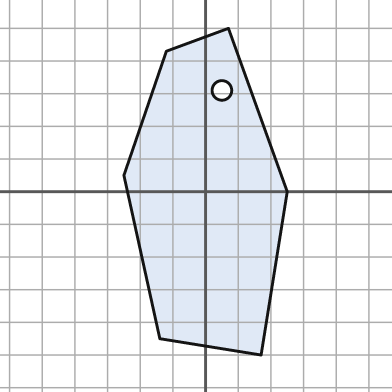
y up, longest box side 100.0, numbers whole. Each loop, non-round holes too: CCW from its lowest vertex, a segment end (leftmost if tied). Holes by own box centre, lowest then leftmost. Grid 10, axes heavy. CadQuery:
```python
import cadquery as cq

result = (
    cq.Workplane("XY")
    .moveTo(17.0, -50.0)
    .lineTo(25.0, 0.0)
    .lineTo(7.0, 50.0)
    .lineTo(-12.0, 43.0)
    .lineTo(-25.0, 5.0)
    .lineTo(-14.0, -45.0)
    .close()
    .moveTo(5.0, 31.0)
    .circle(3.0)
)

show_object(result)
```